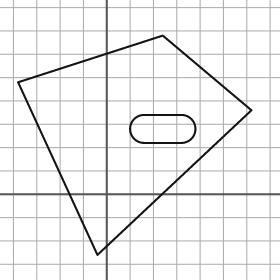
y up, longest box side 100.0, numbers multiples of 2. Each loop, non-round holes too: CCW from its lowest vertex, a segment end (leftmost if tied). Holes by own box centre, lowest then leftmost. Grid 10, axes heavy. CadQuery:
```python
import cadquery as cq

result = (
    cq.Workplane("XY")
    .moveTo(-4.0, -26.0)
    .lineTo(62.0, 36.0)
    .lineTo(24.0, 68.0)
    .lineTo(-38.0, 48.0)
    .close()
    .moveTo(16.0, 22.0)
    .lineTo(32.0, 22.0)
    .threePointArc((38.0, 28.0), (32.0, 34.0))
    .lineTo(16.0, 34.0)
    .threePointArc((10.0, 28.0), (16.0, 22.0))
    .close()
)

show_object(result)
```